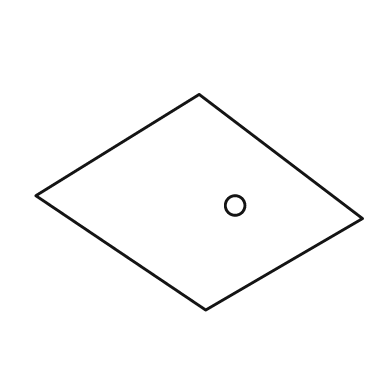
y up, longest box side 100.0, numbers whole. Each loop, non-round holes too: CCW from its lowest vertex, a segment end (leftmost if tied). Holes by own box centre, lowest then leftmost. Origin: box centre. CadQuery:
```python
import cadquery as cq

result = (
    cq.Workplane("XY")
    .moveTo(2.0, -33.0)
    .lineTo(50.0, -5.0)
    .lineTo(0.0, 33.0)
    .lineTo(-50.0, 2.0)
    .close()
    .moveTo(11.0, -1.0)
    .circle(3.0)
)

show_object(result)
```